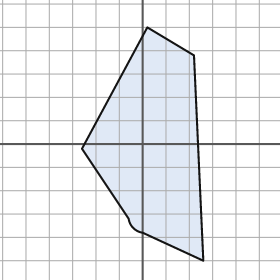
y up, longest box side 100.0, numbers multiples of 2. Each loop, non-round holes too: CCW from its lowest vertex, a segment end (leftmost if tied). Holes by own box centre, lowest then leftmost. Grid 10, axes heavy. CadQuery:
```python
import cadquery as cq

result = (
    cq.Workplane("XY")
    .moveTo(26.0, -50.0)
    .lineTo(22.0, 38.0)
    .lineTo(2.0, 50.0)
    .lineTo(-26.0, -2.0)
    .lineTo(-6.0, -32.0)
    .threePointArc((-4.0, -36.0), (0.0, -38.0))
    .close()
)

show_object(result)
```